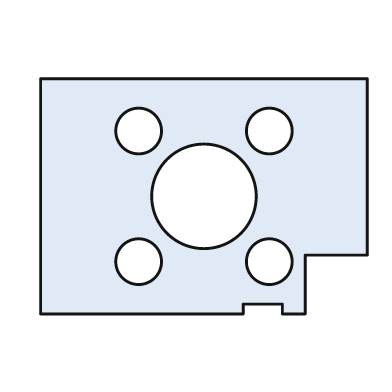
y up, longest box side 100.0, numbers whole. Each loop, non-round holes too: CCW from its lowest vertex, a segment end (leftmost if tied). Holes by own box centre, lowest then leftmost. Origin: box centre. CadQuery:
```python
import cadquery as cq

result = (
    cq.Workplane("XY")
    .moveTo(-50.0, -36.0)
    .lineTo(12.0, -36.0)
    .lineTo(12.0, -33.0)
    .lineTo(24.0, -33.0)
    .lineTo(24.0, -36.0)
    .lineTo(31.0, -36.0)
    .lineTo(31.0, -18.0)
    .lineTo(50.0, -18.0)
    .lineTo(50.0, 36.0)
    .lineTo(-50.0, 36.0)
    .close()
    .moveTo(-20.0, -20.0)
    .circle(7.0)
    .moveTo(20.0, -20.0)
    .circle(7.0)
    .moveTo(0.0, 0.0)
    .circle(16.0)
    .moveTo(-20.0, 20.0)
    .circle(7.0)
    .moveTo(20.0, 20.0)
    .circle(7.0)
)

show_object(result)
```